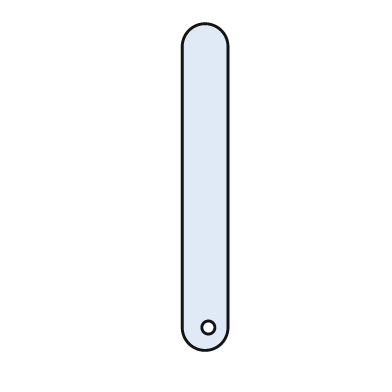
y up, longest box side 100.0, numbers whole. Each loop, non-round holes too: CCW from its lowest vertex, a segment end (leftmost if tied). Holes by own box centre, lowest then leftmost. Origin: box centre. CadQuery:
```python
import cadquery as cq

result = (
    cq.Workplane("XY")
    .moveTo(-7.0, -43.0)
    .threePointArc((0.0, -50.0), (7.0, -43.0))
    .lineTo(7.0, 43.0)
    .threePointArc((0.0, 50.0), (-7.0, 43.0))
    .close()
    .moveTo(1.0, -43.0)
    .circle(2.0)
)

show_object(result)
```